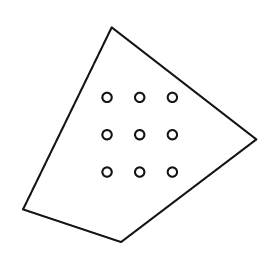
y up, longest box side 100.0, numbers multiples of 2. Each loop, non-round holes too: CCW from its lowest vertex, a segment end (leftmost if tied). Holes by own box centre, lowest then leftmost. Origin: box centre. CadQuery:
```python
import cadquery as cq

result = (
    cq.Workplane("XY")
    .moveTo(-8.0, -46.0)
    .lineTo(50.0, -2.0)
    .lineTo(-12.0, 46.0)
    .lineTo(-50.0, -32.0)
    .close()
    .moveTo(-14.0, -16.0)
    .circle(2.0)
    .moveTo(0.0, -16.0)
    .circle(2.0)
    .moveTo(14.0, -16.0)
    .circle(2.0)
    .moveTo(-14.0, 0.0)
    .circle(2.0)
    .moveTo(0.0, 0.0)
    .circle(2.0)
    .moveTo(14.0, 0.0)
    .circle(2.0)
    .moveTo(-14.0, 16.0)
    .circle(2.0)
    .moveTo(0.0, 16.0)
    .circle(2.0)
    .moveTo(14.0, 16.0)
    .circle(2.0)
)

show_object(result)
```